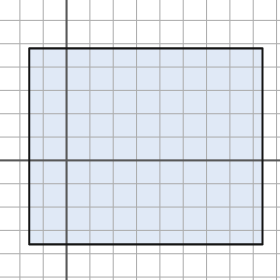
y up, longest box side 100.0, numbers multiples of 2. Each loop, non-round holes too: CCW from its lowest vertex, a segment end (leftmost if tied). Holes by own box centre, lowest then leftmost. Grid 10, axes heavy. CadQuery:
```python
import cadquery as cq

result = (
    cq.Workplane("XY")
    .moveTo(-16.0, -36.0)
    .lineTo(84.0, -36.0)
    .lineTo(84.0, 48.0)
    .lineTo(-16.0, 48.0)
    .close()
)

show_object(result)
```